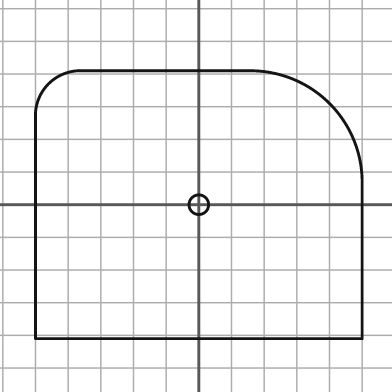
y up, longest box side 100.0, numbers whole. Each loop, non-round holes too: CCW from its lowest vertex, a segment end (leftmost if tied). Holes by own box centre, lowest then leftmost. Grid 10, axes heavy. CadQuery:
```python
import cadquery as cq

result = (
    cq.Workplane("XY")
    .moveTo(-50.0, -41.0)
    .lineTo(50.0, -41.0)
    .lineTo(50.0, 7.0)
    .threePointArc((40.0, 31.0), (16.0, 41.0))
    .lineTo(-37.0, 41.0)
    .threePointArc((-46.0, 37.0), (-50.0, 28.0))
    .close()
    .moveTo(0.0, 0.0)
    .circle(3.0)
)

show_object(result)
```